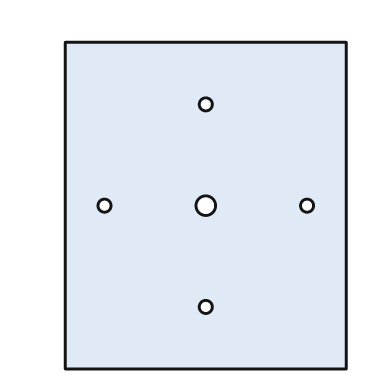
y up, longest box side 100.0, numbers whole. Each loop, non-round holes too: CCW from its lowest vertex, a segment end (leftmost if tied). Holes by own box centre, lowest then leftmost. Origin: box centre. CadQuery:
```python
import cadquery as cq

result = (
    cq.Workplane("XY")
    .moveTo(-43.0, -50.0)
    .lineTo(43.0, -50.0)
    .lineTo(43.0, 50.0)
    .lineTo(-43.0, 50.0)
    .close()
    .moveTo(0.0, -31.0)
    .circle(2.0)
    .moveTo(-31.0, 0.0)
    .circle(2.0)
    .moveTo(0.0, 0.0)
    .circle(3.0)
    .moveTo(31.0, 0.0)
    .circle(2.0)
    .moveTo(0.0, 31.0)
    .circle(2.0)
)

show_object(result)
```